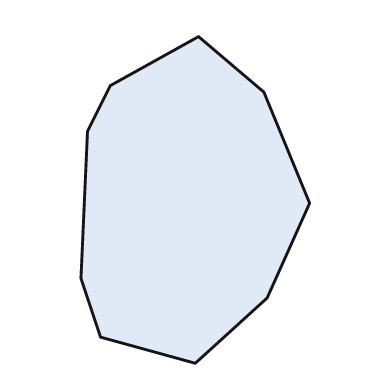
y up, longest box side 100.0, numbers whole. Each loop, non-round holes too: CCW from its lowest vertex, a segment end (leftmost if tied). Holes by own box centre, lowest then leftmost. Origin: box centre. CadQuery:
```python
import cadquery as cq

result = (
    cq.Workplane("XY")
    .moveTo(0.0, -50.0)
    .lineTo(22.0, -30.0)
    .lineTo(35.0, -1.0)
    .lineTo(21.0, 33.0)
    .lineTo(1.0, 50.0)
    .lineTo(-26.0, 35.0)
    .lineTo(-33.0, 21.0)
    .lineTo(-35.0, -24.0)
    .lineTo(-29.0, -42.0)
    .close()
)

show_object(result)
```